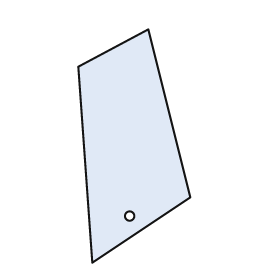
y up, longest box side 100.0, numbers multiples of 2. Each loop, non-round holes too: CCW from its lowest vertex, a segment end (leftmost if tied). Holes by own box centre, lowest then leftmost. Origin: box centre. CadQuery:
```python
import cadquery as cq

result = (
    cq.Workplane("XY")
    .moveTo(-18.0, -50.0)
    .lineTo(24.0, -22.0)
    .lineTo(6.0, 50.0)
    .lineTo(-24.0, 34.0)
    .close()
    .moveTo(-2.0, -30.0)
    .circle(2.0)
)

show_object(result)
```